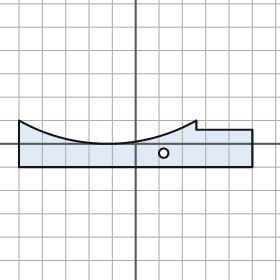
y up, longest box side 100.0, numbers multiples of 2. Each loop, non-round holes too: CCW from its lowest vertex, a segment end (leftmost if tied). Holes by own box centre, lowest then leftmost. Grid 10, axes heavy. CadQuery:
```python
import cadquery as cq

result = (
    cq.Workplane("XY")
    .moveTo(-50.0, -10.0)
    .lineTo(50.0, -10.0)
    .lineTo(50.0, 6.0)
    .lineTo(26.0, 6.0)
    .lineTo(26.0, 10.0)
    .threePointArc((-12.0, 0.0), (-50.0, 10.0))
    .close()
    .moveTo(12.0, -4.0)
    .circle(2.0)
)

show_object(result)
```